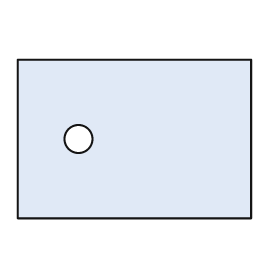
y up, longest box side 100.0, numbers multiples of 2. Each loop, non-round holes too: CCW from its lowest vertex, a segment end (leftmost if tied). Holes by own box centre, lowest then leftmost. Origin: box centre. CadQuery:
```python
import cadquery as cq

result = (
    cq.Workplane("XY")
    .moveTo(-50.0, -34.0)
    .lineTo(50.0, -34.0)
    .lineTo(50.0, 34.0)
    .lineTo(-50.0, 34.0)
    .close()
    .moveTo(-24.0, 0.0)
    .circle(6.0)
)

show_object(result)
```